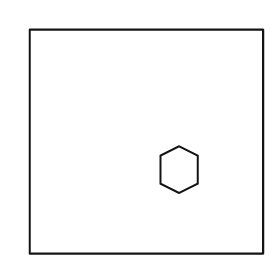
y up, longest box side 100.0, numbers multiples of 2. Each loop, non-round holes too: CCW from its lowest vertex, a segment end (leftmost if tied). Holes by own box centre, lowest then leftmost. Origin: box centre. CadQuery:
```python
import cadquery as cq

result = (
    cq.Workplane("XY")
    .moveTo(-50.0, -48.0)
    .lineTo(50.0, -48.0)
    .lineTo(50.0, 48.0)
    .lineTo(-50.0, 48.0)
    .close()
    .moveTo(14.0, -22.0)
    .lineTo(22.0, -18.0)
    .lineTo(22.0, -6.0)
    .lineTo(14.0, -2.0)
    .lineTo(6.0, -6.0)
    .lineTo(6.0, -18.0)
    .close()
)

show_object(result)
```